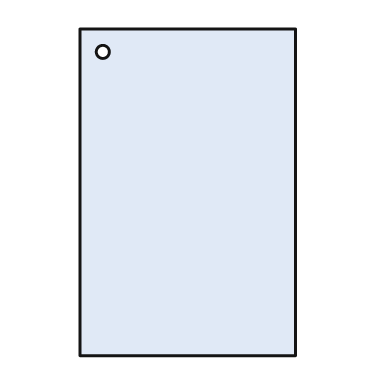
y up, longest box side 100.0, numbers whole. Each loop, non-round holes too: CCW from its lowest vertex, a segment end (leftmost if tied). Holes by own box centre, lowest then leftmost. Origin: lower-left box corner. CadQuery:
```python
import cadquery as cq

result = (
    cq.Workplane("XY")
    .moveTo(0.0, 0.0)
    .lineTo(66.0, 0.0)
    .lineTo(66.0, 100.0)
    .lineTo(0.0, 100.0)
    .close()
    .moveTo(7.0, 93.0)
    .circle(2.0)
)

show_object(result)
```